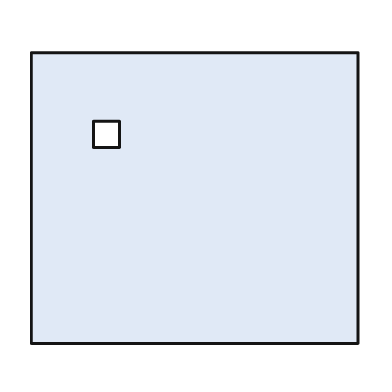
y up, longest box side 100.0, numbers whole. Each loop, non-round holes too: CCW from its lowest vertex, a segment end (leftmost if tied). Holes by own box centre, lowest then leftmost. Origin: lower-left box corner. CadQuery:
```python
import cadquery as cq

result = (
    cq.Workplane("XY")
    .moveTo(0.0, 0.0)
    .lineTo(100.0, 0.0)
    .lineTo(100.0, 89.0)
    .lineTo(0.0, 89.0)
    .close()
    .moveTo(19.0, 60.0)
    .lineTo(27.0, 60.0)
    .lineTo(27.0, 68.0)
    .lineTo(19.0, 68.0)
    .close()
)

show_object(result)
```